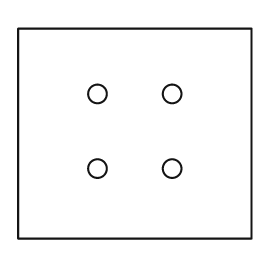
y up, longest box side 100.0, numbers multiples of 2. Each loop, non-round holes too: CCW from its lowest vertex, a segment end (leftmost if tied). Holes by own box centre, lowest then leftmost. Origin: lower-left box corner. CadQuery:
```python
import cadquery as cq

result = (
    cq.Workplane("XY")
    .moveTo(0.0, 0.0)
    .lineTo(100.0, 0.0)
    .lineTo(100.0, 90.0)
    .lineTo(0.0, 90.0)
    .close()
    .moveTo(34.0, 30.0)
    .circle(4.0)
    .moveTo(66.0, 30.0)
    .circle(4.0)
    .moveTo(34.0, 62.0)
    .circle(4.0)
    .moveTo(66.0, 62.0)
    .circle(4.0)
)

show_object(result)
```